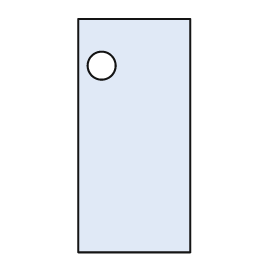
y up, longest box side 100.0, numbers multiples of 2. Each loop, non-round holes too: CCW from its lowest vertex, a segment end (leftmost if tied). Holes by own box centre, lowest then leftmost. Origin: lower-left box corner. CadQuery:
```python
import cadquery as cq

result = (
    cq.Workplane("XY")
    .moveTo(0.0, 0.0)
    .lineTo(48.0, 0.0)
    .lineTo(48.0, 100.0)
    .lineTo(0.0, 100.0)
    .close()
    .moveTo(10.0, 80.0)
    .circle(6.0)
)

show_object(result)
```